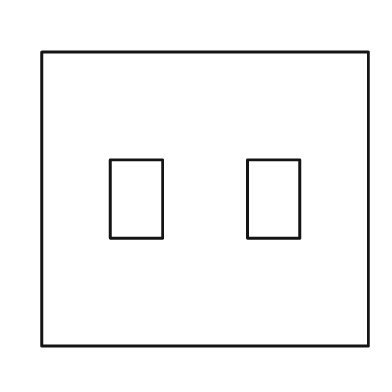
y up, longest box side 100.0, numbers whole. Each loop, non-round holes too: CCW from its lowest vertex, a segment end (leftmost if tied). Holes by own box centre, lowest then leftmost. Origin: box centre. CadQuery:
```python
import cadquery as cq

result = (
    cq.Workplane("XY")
    .moveTo(-50.0, -45.0)
    .lineTo(50.0, -45.0)
    .lineTo(50.0, 45.0)
    .lineTo(-50.0, 45.0)
    .close()
    .moveTo(-29.0, -12.0)
    .lineTo(-13.0, -12.0)
    .lineTo(-13.0, 12.0)
    .lineTo(-29.0, 12.0)
    .close()
    .moveTo(13.0, -12.0)
    .lineTo(29.0, -12.0)
    .lineTo(29.0, 12.0)
    .lineTo(13.0, 12.0)
    .close()
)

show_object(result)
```